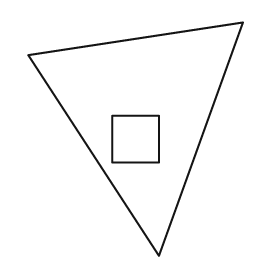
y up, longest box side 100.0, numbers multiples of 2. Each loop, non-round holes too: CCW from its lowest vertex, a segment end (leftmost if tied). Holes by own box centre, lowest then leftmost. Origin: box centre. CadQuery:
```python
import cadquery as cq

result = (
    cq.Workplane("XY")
    .moveTo(10.0, -50.0)
    .lineTo(46.0, 50.0)
    .lineTo(-46.0, 36.0)
    .close()
    .moveTo(-10.0, -10.0)
    .lineTo(10.0, -10.0)
    .lineTo(10.0, 10.0)
    .lineTo(-10.0, 10.0)
    .close()
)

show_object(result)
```